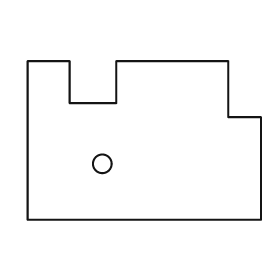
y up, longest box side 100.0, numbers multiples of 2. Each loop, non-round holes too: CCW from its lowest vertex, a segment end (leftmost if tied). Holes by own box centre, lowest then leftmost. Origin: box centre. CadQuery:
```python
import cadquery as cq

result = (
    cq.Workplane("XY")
    .moveTo(-50.0, -34.0)
    .lineTo(50.0, -34.0)
    .lineTo(50.0, 10.0)
    .lineTo(36.0, 10.0)
    .lineTo(36.0, 34.0)
    .lineTo(-12.0, 34.0)
    .lineTo(-12.0, 16.0)
    .lineTo(-32.0, 16.0)
    .lineTo(-32.0, 34.0)
    .lineTo(-50.0, 34.0)
    .close()
    .moveTo(-18.0, -10.0)
    .circle(4.0)
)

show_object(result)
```